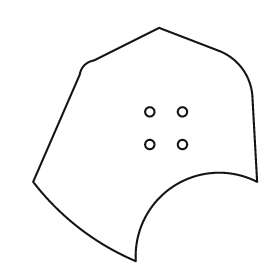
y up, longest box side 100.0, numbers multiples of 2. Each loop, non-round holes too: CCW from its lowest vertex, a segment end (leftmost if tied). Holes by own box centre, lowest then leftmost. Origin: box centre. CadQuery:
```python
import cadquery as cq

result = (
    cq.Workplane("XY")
    .moveTo(-4.0, -50.0)
    .threePointArc((12.0, -18.0), (48.0, -16.0))
    .lineTo(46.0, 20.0)
    .threePointArc((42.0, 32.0), (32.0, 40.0))
    .lineTo(6.0, 50.0)
    .lineTo(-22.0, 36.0)
    .threePointArc((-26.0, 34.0), (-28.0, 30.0))
    .lineTo(-48.0, -16.0)
    .threePointArc((-28.0, -36.0), (-4.0, -50.0))
    .close()
    .moveTo(2.0, 0.0)
    .circle(2.0)
    .moveTo(16.0, 0.0)
    .circle(2.0)
    .moveTo(2.0, 14.0)
    .circle(2.0)
    .moveTo(16.0, 14.0)
    .circle(2.0)
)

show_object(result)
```